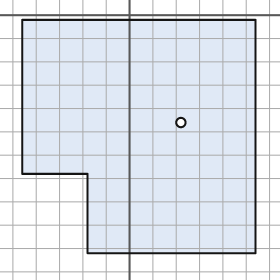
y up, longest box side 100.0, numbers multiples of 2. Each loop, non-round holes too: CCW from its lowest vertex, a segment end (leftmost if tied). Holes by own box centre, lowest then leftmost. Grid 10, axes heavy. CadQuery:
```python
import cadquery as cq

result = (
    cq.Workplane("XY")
    .moveTo(-18.0, -102.0)
    .lineTo(54.0, -102.0)
    .lineTo(54.0, -2.0)
    .lineTo(-46.0, -2.0)
    .lineTo(-46.0, -68.0)
    .lineTo(-18.0, -68.0)
    .close()
    .moveTo(22.0, -46.0)
    .circle(2.0)
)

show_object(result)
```